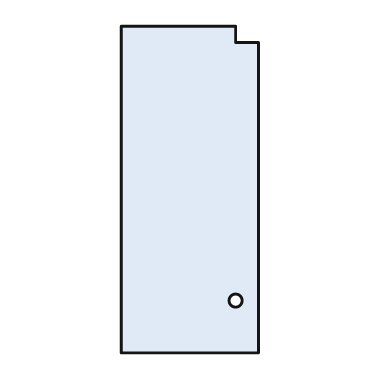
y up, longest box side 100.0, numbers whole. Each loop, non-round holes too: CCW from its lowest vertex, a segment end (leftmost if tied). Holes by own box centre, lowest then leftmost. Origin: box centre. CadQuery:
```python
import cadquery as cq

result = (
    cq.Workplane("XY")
    .moveTo(-21.0, -50.0)
    .lineTo(21.0, -50.0)
    .lineTo(21.0, 45.0)
    .lineTo(14.0, 45.0)
    .lineTo(14.0, 50.0)
    .lineTo(-21.0, 50.0)
    .close()
    .moveTo(14.0, -34.0)
    .circle(2.0)
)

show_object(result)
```